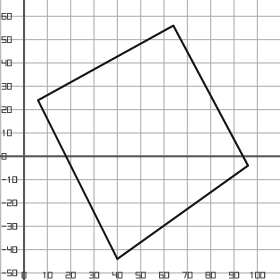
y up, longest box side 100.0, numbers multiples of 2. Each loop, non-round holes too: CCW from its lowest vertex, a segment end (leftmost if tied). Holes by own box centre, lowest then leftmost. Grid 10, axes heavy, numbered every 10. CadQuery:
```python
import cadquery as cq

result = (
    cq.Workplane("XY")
    .moveTo(40.0, -44.0)
    .lineTo(96.0, -4.0)
    .lineTo(64.0, 56.0)
    .lineTo(6.0, 24.0)
    .close()
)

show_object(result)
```